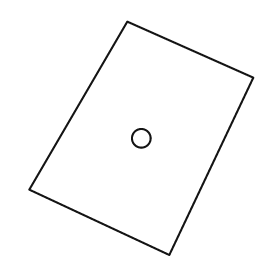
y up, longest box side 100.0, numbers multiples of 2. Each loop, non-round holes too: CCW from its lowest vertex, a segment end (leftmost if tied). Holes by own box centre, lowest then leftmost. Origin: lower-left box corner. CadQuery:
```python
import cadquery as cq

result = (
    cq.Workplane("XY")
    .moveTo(60.0, 0.0)
    .lineTo(96.0, 76.0)
    .lineTo(42.0, 100.0)
    .lineTo(0.0, 28.0)
    .close()
    .moveTo(48.0, 50.0)
    .circle(4.0)
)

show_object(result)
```